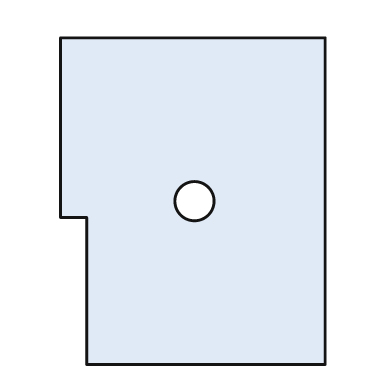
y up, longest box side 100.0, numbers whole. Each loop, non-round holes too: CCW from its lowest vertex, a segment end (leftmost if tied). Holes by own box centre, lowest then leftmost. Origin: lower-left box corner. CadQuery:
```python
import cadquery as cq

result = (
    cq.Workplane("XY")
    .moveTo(8.0, 0.0)
    .lineTo(81.0, 0.0)
    .lineTo(81.0, 100.0)
    .lineTo(0.0, 100.0)
    .lineTo(0.0, 45.0)
    .lineTo(8.0, 45.0)
    .close()
    .moveTo(41.0, 50.0)
    .circle(6.0)
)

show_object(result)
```